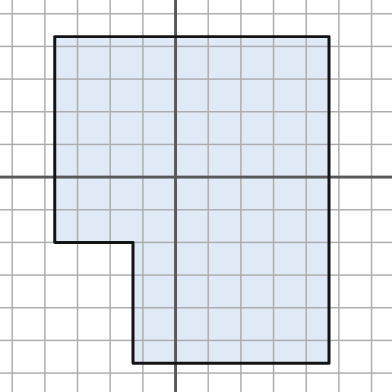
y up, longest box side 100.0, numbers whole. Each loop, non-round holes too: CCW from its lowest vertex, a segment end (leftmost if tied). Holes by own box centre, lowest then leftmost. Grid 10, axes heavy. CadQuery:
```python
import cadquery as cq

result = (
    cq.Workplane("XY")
    .moveTo(-13.0, -57.0)
    .lineTo(47.0, -57.0)
    .lineTo(47.0, 43.0)
    .lineTo(-37.0, 43.0)
    .lineTo(-37.0, -20.0)
    .lineTo(-13.0, -20.0)
    .close()
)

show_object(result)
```